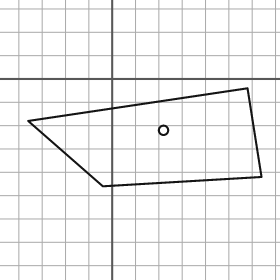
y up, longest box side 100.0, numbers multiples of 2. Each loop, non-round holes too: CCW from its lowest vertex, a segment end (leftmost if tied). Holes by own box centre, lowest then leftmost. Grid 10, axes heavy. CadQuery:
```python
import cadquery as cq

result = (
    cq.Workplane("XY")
    .moveTo(-4.0, -46.0)
    .lineTo(64.0, -42.0)
    .lineTo(58.0, -4.0)
    .lineTo(-36.0, -18.0)
    .close()
    .moveTo(22.0, -22.0)
    .circle(2.0)
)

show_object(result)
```